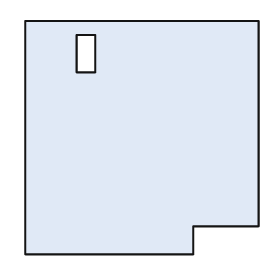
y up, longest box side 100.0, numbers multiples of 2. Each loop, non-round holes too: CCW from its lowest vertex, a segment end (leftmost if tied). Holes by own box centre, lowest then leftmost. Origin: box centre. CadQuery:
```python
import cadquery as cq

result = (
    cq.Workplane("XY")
    .moveTo(-50.0, -50.0)
    .lineTo(22.0, -50.0)
    .lineTo(22.0, -38.0)
    .lineTo(50.0, -38.0)
    .lineTo(50.0, 50.0)
    .lineTo(-50.0, 50.0)
    .close()
    .moveTo(-28.0, 28.0)
    .lineTo(-20.0, 28.0)
    .lineTo(-20.0, 44.0)
    .lineTo(-28.0, 44.0)
    .close()
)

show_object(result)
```